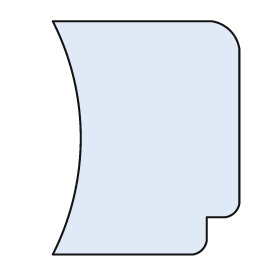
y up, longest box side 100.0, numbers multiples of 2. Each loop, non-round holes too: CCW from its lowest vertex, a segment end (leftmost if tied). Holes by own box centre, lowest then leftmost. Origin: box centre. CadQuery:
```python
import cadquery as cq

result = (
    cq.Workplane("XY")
    .moveTo(-40.0, -50.0)
    .lineTo(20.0, -50.0)
    .threePointArc((24.0, -48.0), (26.0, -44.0))
    .lineTo(26.0, -34.0)
    .lineTo(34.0, -34.0)
    .threePointArc((38.0, -32.0), (40.0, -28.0))
    .lineTo(40.0, 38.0)
    .threePointArc((36.0, 46.0), (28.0, 50.0))
    .lineTo(-40.0, 50.0)
    .threePointArc((-28.0, 0.0), (-40.0, -50.0))
    .close()
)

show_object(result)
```